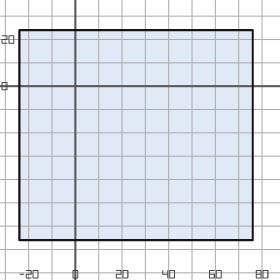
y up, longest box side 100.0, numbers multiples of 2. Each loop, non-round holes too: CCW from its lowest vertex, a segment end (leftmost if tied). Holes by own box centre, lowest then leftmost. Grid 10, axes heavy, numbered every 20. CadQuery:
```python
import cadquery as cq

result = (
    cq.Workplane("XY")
    .moveTo(-24.0, -66.0)
    .lineTo(76.0, -66.0)
    .lineTo(76.0, 24.0)
    .lineTo(-24.0, 24.0)
    .close()
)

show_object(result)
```